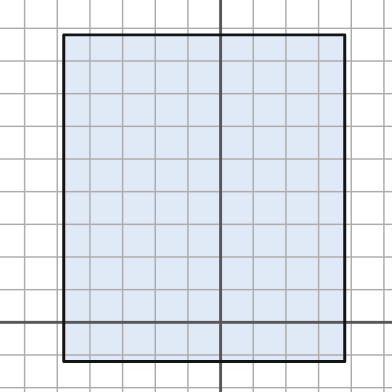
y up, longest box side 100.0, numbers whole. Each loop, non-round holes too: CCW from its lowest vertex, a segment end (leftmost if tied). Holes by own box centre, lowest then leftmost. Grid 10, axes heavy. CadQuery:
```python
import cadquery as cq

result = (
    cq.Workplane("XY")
    .moveTo(-48.0, -12.0)
    .lineTo(38.0, -12.0)
    .lineTo(38.0, 88.0)
    .lineTo(-48.0, 88.0)
    .close()
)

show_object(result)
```